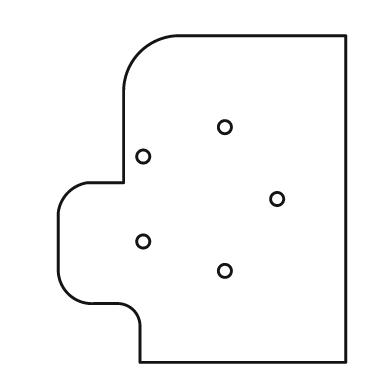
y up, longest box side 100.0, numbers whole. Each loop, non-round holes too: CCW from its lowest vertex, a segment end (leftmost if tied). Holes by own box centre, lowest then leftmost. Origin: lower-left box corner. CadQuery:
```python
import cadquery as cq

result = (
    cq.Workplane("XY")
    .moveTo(25.0, 0.0)
    .lineTo(88.0, 0.0)
    .lineTo(88.0, 100.0)
    .lineTo(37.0, 100.0)
    .threePointArc((25.0, 95.0), (20.0, 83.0))
    .lineTo(20.0, 55.0)
    .lineTo(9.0, 55.0)
    .threePointArc((3.0, 52.0), (0.0, 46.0))
    .lineTo(0.0, 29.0)
    .threePointArc((3.0, 21.0), (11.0, 18.0))
    .lineTo(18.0, 18.0)
    .threePointArc((23.0, 16.0), (25.0, 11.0))
    .close()
    .moveTo(51.0, 28.0)
    .circle(2.0)
    .moveTo(26.0, 37.0)
    .circle(2.0)
    .moveTo(67.0, 50.0)
    .circle(2.0)
    .moveTo(26.0, 63.0)
    .circle(2.0)
    .moveTo(51.0, 72.0)
    .circle(2.0)
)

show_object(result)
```